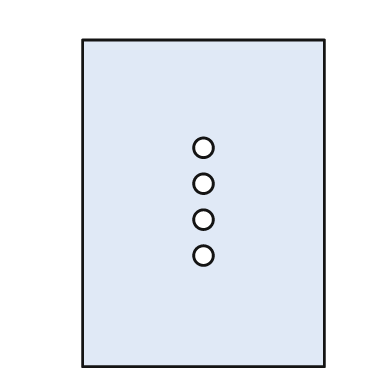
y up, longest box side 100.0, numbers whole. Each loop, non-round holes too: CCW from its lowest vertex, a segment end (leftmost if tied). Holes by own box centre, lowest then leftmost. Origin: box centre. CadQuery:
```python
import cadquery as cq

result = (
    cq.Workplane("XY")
    .moveTo(-37.0, -50.0)
    .lineTo(37.0, -50.0)
    .lineTo(37.0, 50.0)
    .lineTo(-37.0, 50.0)
    .close()
    .moveTo(0.0, -16.0)
    .circle(3.0)
    .moveTo(0.0, -5.0)
    .circle(3.0)
    .moveTo(0.0, 6.0)
    .circle(3.0)
    .moveTo(0.0, 17.0)
    .circle(3.0)
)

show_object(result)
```